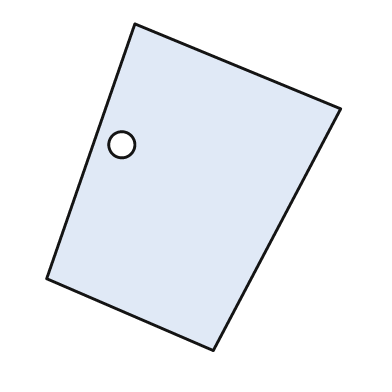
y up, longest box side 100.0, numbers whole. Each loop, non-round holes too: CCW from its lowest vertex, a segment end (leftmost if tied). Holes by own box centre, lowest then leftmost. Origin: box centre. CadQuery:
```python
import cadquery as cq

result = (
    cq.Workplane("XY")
    .moveTo(6.0, -50.0)
    .lineTo(45.0, 24.0)
    .lineTo(-18.0, 50.0)
    .lineTo(-45.0, -28.0)
    .close()
    .moveTo(-22.0, 13.0)
    .circle(4.0)
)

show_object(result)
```